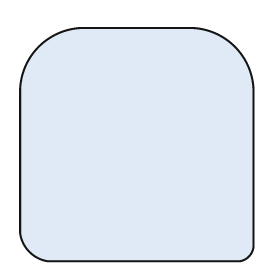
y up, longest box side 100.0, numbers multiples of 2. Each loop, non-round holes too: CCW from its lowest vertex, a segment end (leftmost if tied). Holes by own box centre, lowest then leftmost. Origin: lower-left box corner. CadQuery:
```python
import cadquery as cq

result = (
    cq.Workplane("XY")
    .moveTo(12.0, 0.0)
    .lineTo(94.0, 0.0)
    .threePointArc((98.0, 2.0), (100.0, 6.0))
    .lineTo(100.0, 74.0)
    .threePointArc((92.0, 92.0), (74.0, 100.0))
    .lineTo(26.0, 100.0)
    .threePointArc((8.0, 92.0), (0.0, 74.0))
    .lineTo(0.0, 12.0)
    .threePointArc((4.0, 4.0), (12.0, 0.0))
    .close()
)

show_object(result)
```